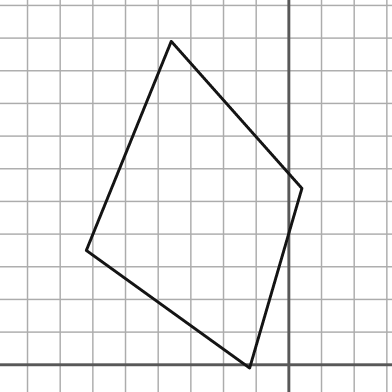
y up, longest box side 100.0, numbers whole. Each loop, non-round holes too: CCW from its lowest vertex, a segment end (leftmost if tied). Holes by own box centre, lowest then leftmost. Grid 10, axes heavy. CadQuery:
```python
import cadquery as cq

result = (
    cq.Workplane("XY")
    .moveTo(-12.0, -1.0)
    .lineTo(4.0, 54.0)
    .lineTo(-36.0, 99.0)
    .lineTo(-62.0, 35.0)
    .close()
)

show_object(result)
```